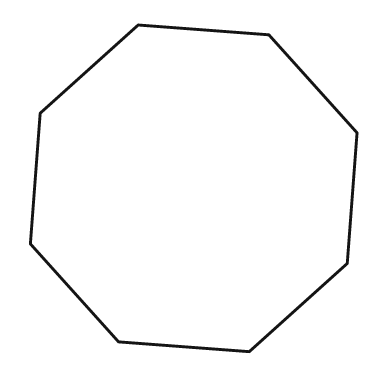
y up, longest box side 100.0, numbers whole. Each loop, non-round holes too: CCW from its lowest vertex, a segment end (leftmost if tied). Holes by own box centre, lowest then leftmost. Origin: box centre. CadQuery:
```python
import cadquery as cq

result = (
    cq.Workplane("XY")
    .moveTo(17.0, -50.0)
    .lineTo(47.0, -23.0)
    .lineTo(50.0, 17.0)
    .lineTo(23.0, 47.0)
    .lineTo(-17.0, 50.0)
    .lineTo(-47.0, 23.0)
    .lineTo(-50.0, -17.0)
    .lineTo(-23.0, -47.0)
    .close()
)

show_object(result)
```